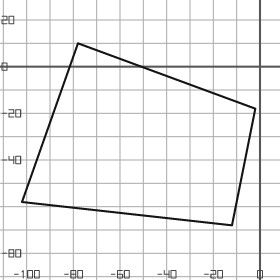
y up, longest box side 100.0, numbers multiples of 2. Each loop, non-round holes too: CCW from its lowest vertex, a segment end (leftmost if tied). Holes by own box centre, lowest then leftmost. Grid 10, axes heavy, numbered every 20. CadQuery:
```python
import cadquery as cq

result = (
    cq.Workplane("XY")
    .moveTo(-12.0, -68.0)
    .lineTo(-2.0, -18.0)
    .lineTo(-78.0, 10.0)
    .lineTo(-102.0, -58.0)
    .close()
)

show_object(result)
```